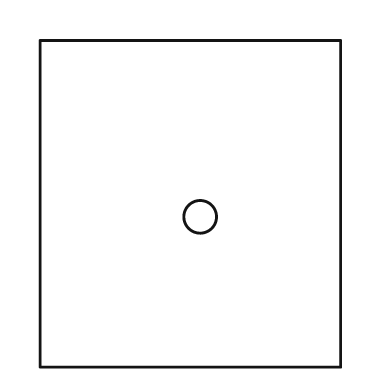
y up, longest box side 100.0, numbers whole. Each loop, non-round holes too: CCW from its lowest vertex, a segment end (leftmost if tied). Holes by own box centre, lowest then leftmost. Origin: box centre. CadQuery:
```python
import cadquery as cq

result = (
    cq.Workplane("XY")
    .moveTo(-46.0, -50.0)
    .lineTo(46.0, -50.0)
    .lineTo(46.0, 50.0)
    .lineTo(-46.0, 50.0)
    .close()
    .moveTo(3.0, -4.0)
    .circle(5.0)
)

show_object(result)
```